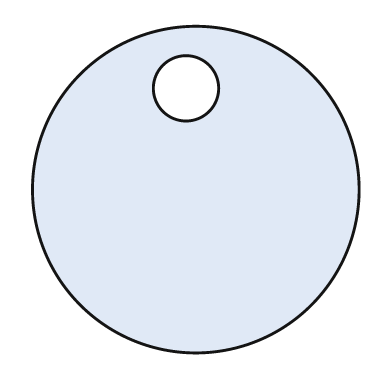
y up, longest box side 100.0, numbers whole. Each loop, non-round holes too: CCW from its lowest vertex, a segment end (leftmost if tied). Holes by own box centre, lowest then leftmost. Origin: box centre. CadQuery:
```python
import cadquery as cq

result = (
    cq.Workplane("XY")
    .moveTo(0.0, 0.0)
    .circle(50.0)
    .moveTo(-3.0, 31.0)
    .circle(10.0)
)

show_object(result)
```